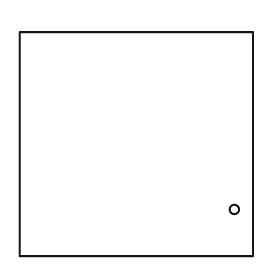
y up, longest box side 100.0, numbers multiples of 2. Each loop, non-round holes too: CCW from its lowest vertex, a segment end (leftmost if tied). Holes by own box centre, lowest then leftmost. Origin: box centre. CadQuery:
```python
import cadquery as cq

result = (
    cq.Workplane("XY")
    .moveTo(-50.0, -48.0)
    .lineTo(50.0, -48.0)
    .lineTo(50.0, 48.0)
    .lineTo(-50.0, 48.0)
    .close()
    .moveTo(42.0, -28.0)
    .circle(2.0)
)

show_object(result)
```